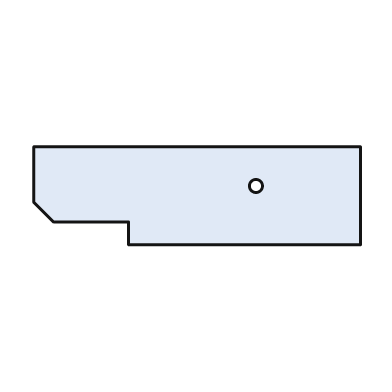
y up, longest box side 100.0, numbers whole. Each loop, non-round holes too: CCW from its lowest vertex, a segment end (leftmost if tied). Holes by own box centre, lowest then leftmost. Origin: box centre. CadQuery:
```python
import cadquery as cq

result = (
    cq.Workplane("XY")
    .moveTo(-21.0, -15.0)
    .lineTo(50.0, -15.0)
    .lineTo(50.0, 15.0)
    .lineTo(-50.0, 15.0)
    .lineTo(-50.0, -2.0)
    .lineTo(-44.0, -8.0)
    .lineTo(-21.0, -8.0)
    .close()
    .moveTo(18.0, 3.0)
    .circle(2.0)
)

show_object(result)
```